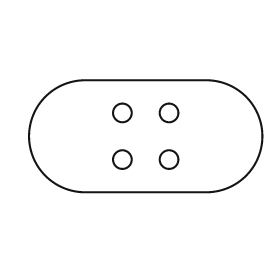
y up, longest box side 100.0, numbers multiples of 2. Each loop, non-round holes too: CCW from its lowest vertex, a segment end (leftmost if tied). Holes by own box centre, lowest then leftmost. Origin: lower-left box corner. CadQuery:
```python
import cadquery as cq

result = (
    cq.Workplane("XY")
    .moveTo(24.0, 0.0)
    .lineTo(76.0, 0.0)
    .threePointArc((100.0, 24.0), (76.0, 48.0))
    .lineTo(24.0, 48.0)
    .threePointArc((0.0, 24.0), (24.0, 0.0))
    .close()
    .moveTo(40.0, 14.0)
    .circle(4.0)
    .moveTo(60.0, 14.0)
    .circle(4.0)
    .moveTo(40.0, 34.0)
    .circle(4.0)
    .moveTo(60.0, 34.0)
    .circle(4.0)
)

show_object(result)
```